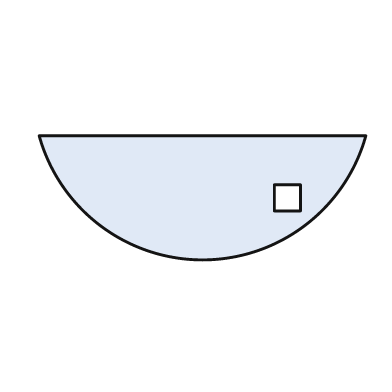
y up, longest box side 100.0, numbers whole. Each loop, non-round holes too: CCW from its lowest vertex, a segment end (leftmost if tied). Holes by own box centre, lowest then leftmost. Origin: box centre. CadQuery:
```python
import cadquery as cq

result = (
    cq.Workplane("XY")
    .moveTo(-50.0, 19.0)
    .threePointArc((0.0, -19.0), (50.0, 19.0))
    .close()
    .moveTo(22.0, -4.0)
    .lineTo(30.0, -4.0)
    .lineTo(30.0, 4.0)
    .lineTo(22.0, 4.0)
    .close()
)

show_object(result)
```